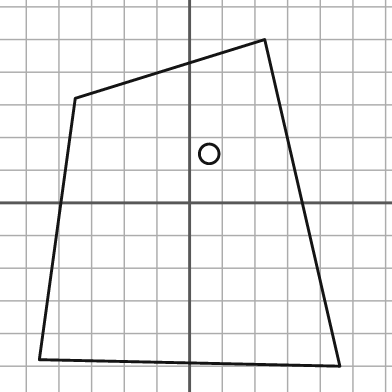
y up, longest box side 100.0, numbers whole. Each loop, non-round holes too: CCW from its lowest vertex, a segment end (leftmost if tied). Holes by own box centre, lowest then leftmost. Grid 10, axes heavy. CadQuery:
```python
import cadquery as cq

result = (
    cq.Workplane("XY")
    .moveTo(46.0, -50.0)
    .lineTo(23.0, 50.0)
    .lineTo(-35.0, 32.0)
    .lineTo(-46.0, -48.0)
    .close()
    .moveTo(6.0, 15.0)
    .circle(3.0)
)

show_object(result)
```